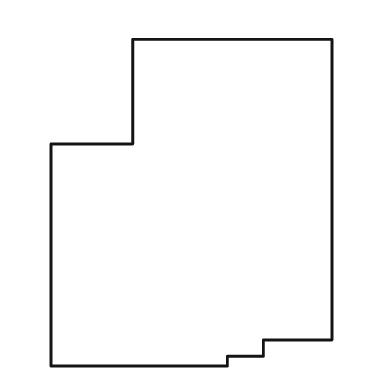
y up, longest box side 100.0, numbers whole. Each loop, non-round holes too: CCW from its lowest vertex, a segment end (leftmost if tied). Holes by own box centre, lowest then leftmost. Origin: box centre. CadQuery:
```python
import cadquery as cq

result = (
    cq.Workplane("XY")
    .moveTo(-43.0, -50.0)
    .lineTo(11.0, -50.0)
    .lineTo(11.0, -47.0)
    .lineTo(22.0, -47.0)
    .lineTo(22.0, -42.0)
    .lineTo(43.0, -42.0)
    .lineTo(43.0, 50.0)
    .lineTo(-18.0, 50.0)
    .lineTo(-18.0, 18.0)
    .lineTo(-43.0, 18.0)
    .close()
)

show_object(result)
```